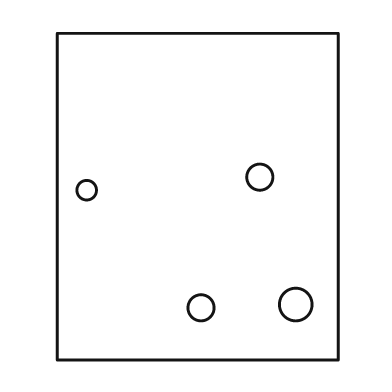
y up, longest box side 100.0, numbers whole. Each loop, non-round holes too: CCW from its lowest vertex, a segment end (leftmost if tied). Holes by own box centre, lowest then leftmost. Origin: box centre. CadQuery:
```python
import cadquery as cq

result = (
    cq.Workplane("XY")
    .moveTo(-43.0, -50.0)
    .lineTo(43.0, -50.0)
    .lineTo(43.0, 50.0)
    .lineTo(-43.0, 50.0)
    .close()
    .moveTo(1.0, -34.0)
    .circle(4.0)
    .moveTo(30.0, -33.0)
    .circle(5.0)
    .moveTo(-34.0, 2.0)
    .circle(3.0)
    .moveTo(19.0, 6.0)
    .circle(4.0)
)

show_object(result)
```